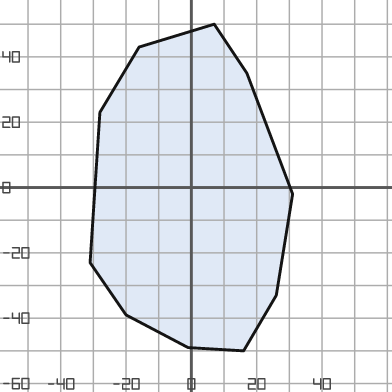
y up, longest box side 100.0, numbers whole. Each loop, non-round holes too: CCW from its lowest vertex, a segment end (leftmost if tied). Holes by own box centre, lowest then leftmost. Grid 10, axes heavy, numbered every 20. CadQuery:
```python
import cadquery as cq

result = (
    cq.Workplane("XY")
    .moveTo(16.0, -50.0)
    .lineTo(26.0, -33.0)
    .lineTo(31.0, -2.0)
    .lineTo(17.0, 35.0)
    .lineTo(7.0, 50.0)
    .lineTo(-16.0, 43.0)
    .lineTo(-28.0, 23.0)
    .lineTo(-31.0, -23.0)
    .lineTo(-20.0, -39.0)
    .lineTo(-1.0, -49.0)
    .close()
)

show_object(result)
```